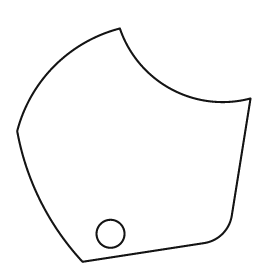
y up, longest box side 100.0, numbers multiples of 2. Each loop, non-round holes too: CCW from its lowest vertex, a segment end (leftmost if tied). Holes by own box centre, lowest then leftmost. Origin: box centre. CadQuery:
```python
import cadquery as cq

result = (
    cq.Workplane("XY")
    .moveTo(-22.0, -50.0)
    .lineTo(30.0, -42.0)
    .threePointArc((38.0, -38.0), (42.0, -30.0))
    .lineTo(50.0, 20.0)
    .threePointArc((16.0, 24.0), (-6.0, 50.0))
    .threePointArc((-34.0, 34.0), (-50.0, 6.0))
    .threePointArc((-40.0, -24.0), (-22.0, -50.0))
    .close()
    .moveTo(-10.0, -38.0)
    .circle(6.0)
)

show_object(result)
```